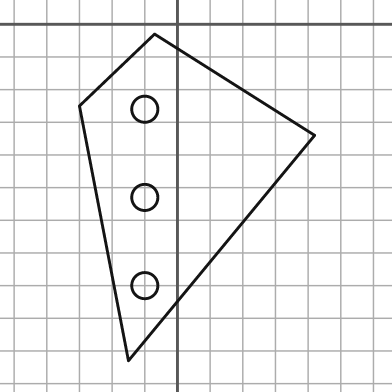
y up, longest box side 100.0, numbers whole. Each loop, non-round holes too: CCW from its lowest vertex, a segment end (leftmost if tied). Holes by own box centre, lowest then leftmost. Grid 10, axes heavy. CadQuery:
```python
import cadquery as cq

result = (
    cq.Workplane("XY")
    .moveTo(-15.0, -103.0)
    .lineTo(42.0, -34.0)
    .lineTo(-7.0, -3.0)
    .lineTo(-30.0, -25.0)
    .close()
    .moveTo(-10.0, -80.0)
    .circle(4.0)
    .moveTo(-10.0, -53.0)
    .circle(4.0)
    .moveTo(-10.0, -26.0)
    .circle(4.0)
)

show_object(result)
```